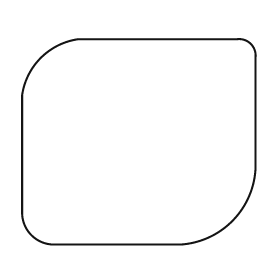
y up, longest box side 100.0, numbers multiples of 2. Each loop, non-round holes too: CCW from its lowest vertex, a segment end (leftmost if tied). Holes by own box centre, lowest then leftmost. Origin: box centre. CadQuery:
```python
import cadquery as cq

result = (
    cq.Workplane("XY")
    .moveTo(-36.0, -44.0)
    .lineTo(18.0, -44.0)
    .threePointArc((40.0, -34.0), (50.0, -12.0))
    .lineTo(50.0, 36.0)
    .threePointArc((48.0, 42.0), (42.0, 44.0))
    .lineTo(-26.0, 44.0)
    .threePointArc((-42.0, 36.0), (-50.0, 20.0))
    .lineTo(-50.0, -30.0)
    .threePointArc((-46.0, -40.0), (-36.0, -44.0))
    .close()
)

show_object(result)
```